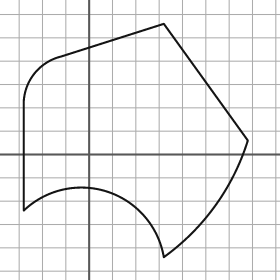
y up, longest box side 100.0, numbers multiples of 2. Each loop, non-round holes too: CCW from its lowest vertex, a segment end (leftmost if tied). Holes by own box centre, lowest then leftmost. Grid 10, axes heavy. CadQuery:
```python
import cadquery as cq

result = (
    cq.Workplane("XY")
    .moveTo(32.0, -44.0)
    .threePointArc((54.0, -22.0), (68.0, 6.0))
    .lineTo(32.0, 56.0)
    .lineTo(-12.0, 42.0)
    .threePointArc((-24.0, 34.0), (-28.0, 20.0))
    .lineTo(-28.0, -24.0)
    .threePointArc((8.0, -16.0), (32.0, -44.0))
    .close()
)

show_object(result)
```